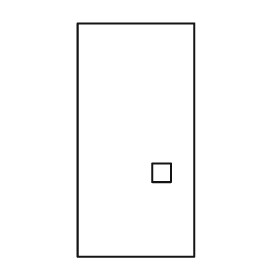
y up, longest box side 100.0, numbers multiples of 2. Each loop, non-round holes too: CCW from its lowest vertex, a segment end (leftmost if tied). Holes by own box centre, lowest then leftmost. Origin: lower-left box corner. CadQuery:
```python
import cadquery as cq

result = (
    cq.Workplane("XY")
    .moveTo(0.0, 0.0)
    .lineTo(50.0, 0.0)
    .lineTo(50.0, 100.0)
    .lineTo(0.0, 100.0)
    .close()
    .moveTo(32.0, 32.0)
    .lineTo(40.0, 32.0)
    .lineTo(40.0, 40.0)
    .lineTo(32.0, 40.0)
    .close()
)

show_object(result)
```